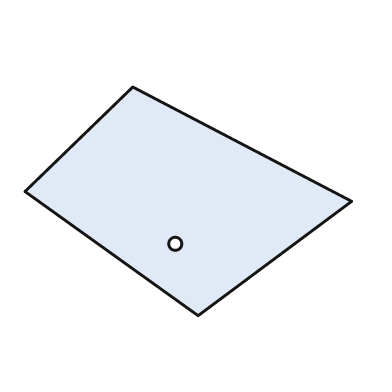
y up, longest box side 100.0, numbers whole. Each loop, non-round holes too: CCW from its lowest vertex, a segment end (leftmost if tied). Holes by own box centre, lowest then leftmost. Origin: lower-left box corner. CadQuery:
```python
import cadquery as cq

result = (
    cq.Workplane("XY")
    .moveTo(53.0, 0.0)
    .lineTo(100.0, 35.0)
    .lineTo(33.0, 70.0)
    .lineTo(0.0, 38.0)
    .close()
    .moveTo(46.0, 22.0)
    .circle(2.0)
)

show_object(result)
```